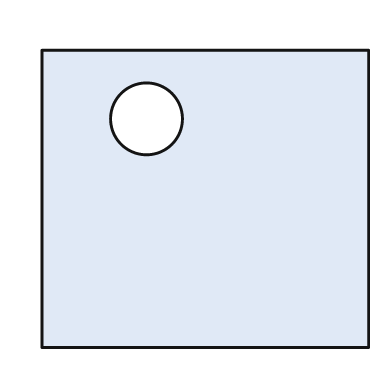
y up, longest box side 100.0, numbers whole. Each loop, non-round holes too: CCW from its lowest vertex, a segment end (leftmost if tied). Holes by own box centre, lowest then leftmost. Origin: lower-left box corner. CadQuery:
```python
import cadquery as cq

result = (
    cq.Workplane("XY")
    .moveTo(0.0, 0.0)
    .lineTo(100.0, 0.0)
    .lineTo(100.0, 91.0)
    .lineTo(0.0, 91.0)
    .close()
    .moveTo(32.0, 70.0)
    .circle(11.0)
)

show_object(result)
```